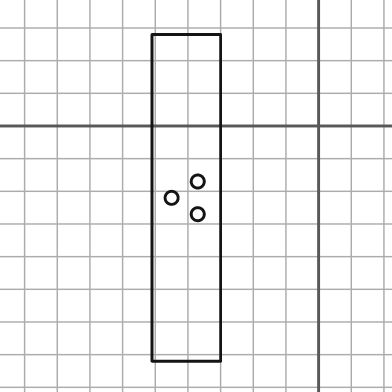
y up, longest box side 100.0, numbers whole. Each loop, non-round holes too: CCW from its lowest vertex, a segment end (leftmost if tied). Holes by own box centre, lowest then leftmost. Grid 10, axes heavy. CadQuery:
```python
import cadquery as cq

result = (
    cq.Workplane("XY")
    .moveTo(-51.0, -72.0)
    .lineTo(-30.0, -72.0)
    .lineTo(-30.0, 28.0)
    .lineTo(-51.0, 28.0)
    .close()
    .moveTo(-37.0, -27.0)
    .circle(2.0)
    .moveTo(-45.0, -22.0)
    .circle(2.0)
    .moveTo(-37.0, -17.0)
    .circle(2.0)
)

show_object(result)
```